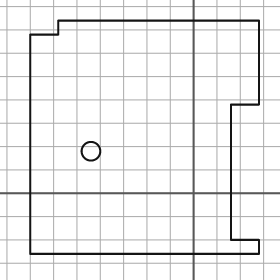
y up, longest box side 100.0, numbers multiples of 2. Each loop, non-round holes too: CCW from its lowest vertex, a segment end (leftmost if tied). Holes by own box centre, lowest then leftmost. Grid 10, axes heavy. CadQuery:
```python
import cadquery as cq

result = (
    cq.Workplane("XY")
    .moveTo(-70.0, -26.0)
    .lineTo(28.0, -26.0)
    .lineTo(28.0, -20.0)
    .lineTo(16.0, -20.0)
    .lineTo(16.0, 38.0)
    .lineTo(28.0, 38.0)
    .lineTo(28.0, 74.0)
    .lineTo(-58.0, 74.0)
    .lineTo(-58.0, 68.0)
    .lineTo(-70.0, 68.0)
    .close()
    .moveTo(-44.0, 18.0)
    .circle(4.0)
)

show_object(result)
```